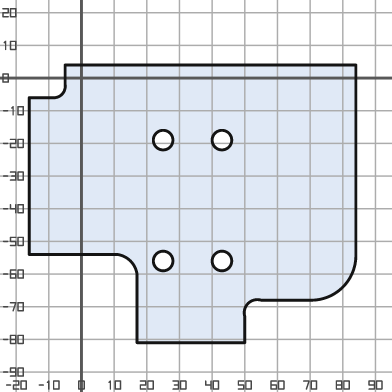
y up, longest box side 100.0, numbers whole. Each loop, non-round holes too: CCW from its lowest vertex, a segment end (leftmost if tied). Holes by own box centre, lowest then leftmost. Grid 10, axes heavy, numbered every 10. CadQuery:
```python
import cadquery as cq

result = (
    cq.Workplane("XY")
    .moveTo(17.0, -81.0)
    .lineTo(50.0, -81.0)
    .lineTo(50.0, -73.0)
    .threePointArc((51.0, -69.0), (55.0, -68.0))
    .lineTo(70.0, -68.0)
    .threePointArc((80.0, -64.0), (84.0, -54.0))
    .lineTo(84.0, 4.0)
    .lineTo(-5.0, 4.0)
    .lineTo(-5.0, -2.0)
    .threePointArc((-6.0, -5.0), (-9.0, -6.0))
    .lineTo(-16.0, -6.0)
    .lineTo(-16.0, -54.0)
    .lineTo(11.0, -54.0)
    .threePointArc((15.0, -56.0), (17.0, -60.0))
    .close()
    .moveTo(25.0, -56.0)
    .circle(3.0)
    .moveTo(43.0, -56.0)
    .circle(3.0)
    .moveTo(25.0, -19.0)
    .circle(3.0)
    .moveTo(43.0, -19.0)
    .circle(3.0)
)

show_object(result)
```